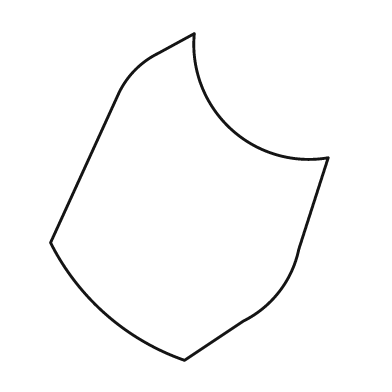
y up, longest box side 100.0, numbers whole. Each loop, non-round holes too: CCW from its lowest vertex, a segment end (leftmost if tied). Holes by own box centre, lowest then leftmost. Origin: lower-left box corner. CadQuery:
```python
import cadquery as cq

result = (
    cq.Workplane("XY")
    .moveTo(41.0, 0.0)
    .lineTo(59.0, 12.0)
    .threePointArc((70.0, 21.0), (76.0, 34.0))
    .lineTo(85.0, 62.0)
    .threePointArc((55.0, 71.0), (44.0, 100.0))
    .lineTo(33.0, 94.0)
    .threePointArc((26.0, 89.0), (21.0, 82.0))
    .lineTo(0.0, 36.0)
    .threePointArc((17.0, 14.0), (41.0, 0.0))
    .close()
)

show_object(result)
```